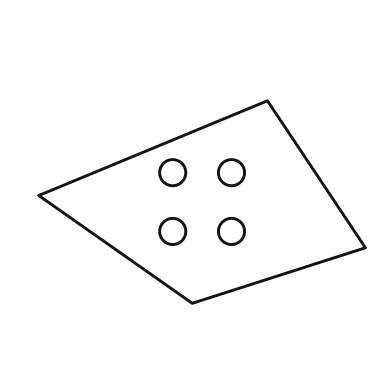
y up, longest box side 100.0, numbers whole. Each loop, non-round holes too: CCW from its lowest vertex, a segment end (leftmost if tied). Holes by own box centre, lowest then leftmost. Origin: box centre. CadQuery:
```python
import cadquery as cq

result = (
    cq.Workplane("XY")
    .moveTo(-3.0, -31.0)
    .lineTo(50.0, -14.0)
    .lineTo(20.0, 31.0)
    .lineTo(-50.0, 2.0)
    .close()
    .moveTo(-9.0, -9.0)
    .circle(4.0)
    .moveTo(9.0, -9.0)
    .circle(4.0)
    .moveTo(-9.0, 9.0)
    .circle(4.0)
    .moveTo(9.0, 9.0)
    .circle(4.0)
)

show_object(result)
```